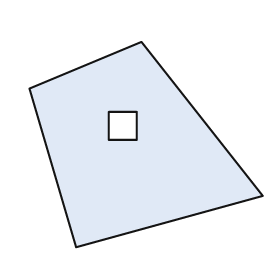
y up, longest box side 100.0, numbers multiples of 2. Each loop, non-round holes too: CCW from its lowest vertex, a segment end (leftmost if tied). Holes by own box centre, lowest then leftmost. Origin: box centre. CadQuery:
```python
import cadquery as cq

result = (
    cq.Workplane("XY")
    .moveTo(-30.0, -44.0)
    .lineTo(50.0, -22.0)
    .lineTo(-2.0, 44.0)
    .lineTo(-50.0, 24.0)
    .close()
    .moveTo(-16.0, 2.0)
    .lineTo(-4.0, 2.0)
    .lineTo(-4.0, 14.0)
    .lineTo(-16.0, 14.0)
    .close()
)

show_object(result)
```